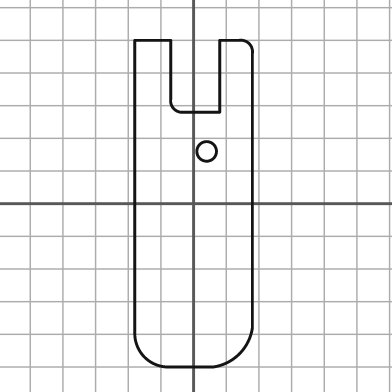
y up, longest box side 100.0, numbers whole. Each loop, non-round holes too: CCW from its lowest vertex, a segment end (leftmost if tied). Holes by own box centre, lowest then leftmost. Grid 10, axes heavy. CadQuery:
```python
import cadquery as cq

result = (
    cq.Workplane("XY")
    .moveTo(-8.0, -50.0)
    .lineTo(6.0, -50.0)
    .threePointArc((14.0, -46.0), (18.0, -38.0))
    .lineTo(18.0, 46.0)
    .threePointArc((17.0, 49.0), (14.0, 50.0))
    .lineTo(8.0, 50.0)
    .lineTo(8.0, 28.0)
    .lineTo(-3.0, 28.0)
    .threePointArc((-6.0, 29.0), (-7.0, 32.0))
    .lineTo(-7.0, 50.0)
    .lineTo(-18.0, 50.0)
    .lineTo(-18.0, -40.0)
    .threePointArc((-15.0, -47.0), (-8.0, -50.0))
    .close()
    .moveTo(4.0, 16.0)
    .circle(3.0)
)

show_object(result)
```